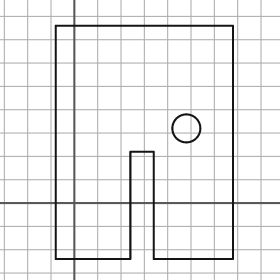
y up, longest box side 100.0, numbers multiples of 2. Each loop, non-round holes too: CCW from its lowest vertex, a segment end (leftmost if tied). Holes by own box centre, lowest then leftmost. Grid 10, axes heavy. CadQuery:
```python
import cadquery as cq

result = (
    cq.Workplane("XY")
    .moveTo(-8.0, -24.0)
    .lineTo(24.0, -24.0)
    .lineTo(24.0, 22.0)
    .lineTo(34.0, 22.0)
    .lineTo(34.0, -24.0)
    .lineTo(68.0, -24.0)
    .lineTo(68.0, 76.0)
    .lineTo(-8.0, 76.0)
    .close()
    .moveTo(48.0, 32.0)
    .circle(6.0)
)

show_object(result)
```